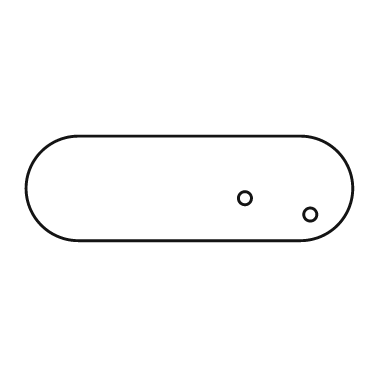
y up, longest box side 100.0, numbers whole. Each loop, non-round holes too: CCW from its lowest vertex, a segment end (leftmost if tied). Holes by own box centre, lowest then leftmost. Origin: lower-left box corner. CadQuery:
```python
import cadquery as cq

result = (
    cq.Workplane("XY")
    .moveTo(16.0, 0.0)
    .lineTo(84.0, 0.0)
    .threePointArc((100.0, 16.0), (84.0, 32.0))
    .lineTo(16.0, 32.0)
    .threePointArc((0.0, 16.0), (16.0, 0.0))
    .close()
    .moveTo(87.0, 8.0)
    .circle(2.0)
    .moveTo(67.0, 13.0)
    .circle(2.0)
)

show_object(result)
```